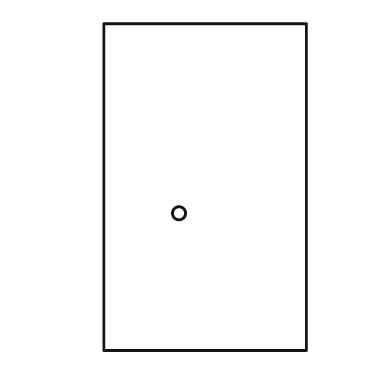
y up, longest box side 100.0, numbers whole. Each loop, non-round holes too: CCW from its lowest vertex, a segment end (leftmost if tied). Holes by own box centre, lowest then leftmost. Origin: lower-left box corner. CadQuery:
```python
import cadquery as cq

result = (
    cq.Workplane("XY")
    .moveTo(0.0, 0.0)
    .lineTo(62.0, 0.0)
    .lineTo(62.0, 100.0)
    .lineTo(0.0, 100.0)
    .close()
    .moveTo(23.0, 42.0)
    .circle(2.0)
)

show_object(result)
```